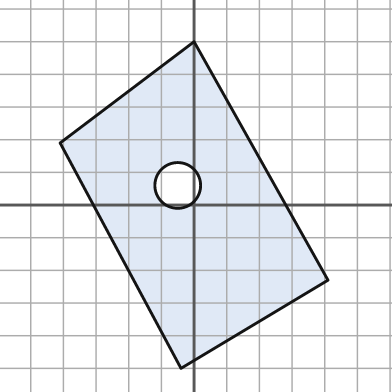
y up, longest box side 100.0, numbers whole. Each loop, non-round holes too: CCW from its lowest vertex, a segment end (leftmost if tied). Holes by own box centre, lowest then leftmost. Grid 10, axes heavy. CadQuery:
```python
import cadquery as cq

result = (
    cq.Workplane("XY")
    .moveTo(-4.0, -50.0)
    .lineTo(41.0, -23.0)
    .lineTo(0.0, 50.0)
    .lineTo(-41.0, 19.0)
    .close()
    .moveTo(-5.0, 6.0)
    .circle(7.0)
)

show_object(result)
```